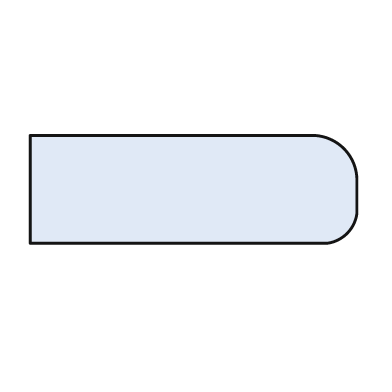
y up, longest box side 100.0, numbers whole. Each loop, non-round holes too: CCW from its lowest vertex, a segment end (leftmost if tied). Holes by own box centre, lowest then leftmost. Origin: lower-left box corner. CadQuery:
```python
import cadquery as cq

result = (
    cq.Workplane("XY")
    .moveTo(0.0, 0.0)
    .lineTo(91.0, 0.0)
    .threePointArc((97.0, 3.0), (100.0, 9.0))
    .lineTo(100.0, 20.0)
    .threePointArc((96.0, 29.0), (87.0, 33.0))
    .lineTo(0.0, 33.0)
    .close()
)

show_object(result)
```